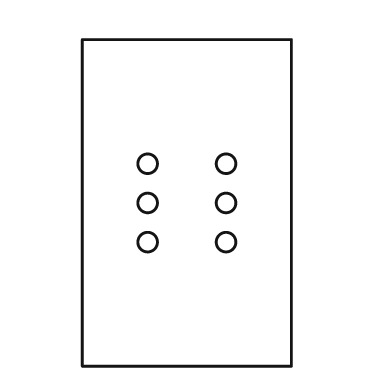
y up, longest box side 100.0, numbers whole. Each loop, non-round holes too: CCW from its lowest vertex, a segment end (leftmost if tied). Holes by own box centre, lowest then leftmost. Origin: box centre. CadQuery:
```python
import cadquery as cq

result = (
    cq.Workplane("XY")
    .moveTo(-32.0, -50.0)
    .lineTo(32.0, -50.0)
    .lineTo(32.0, 50.0)
    .lineTo(-32.0, 50.0)
    .close()
    .moveTo(-12.0, -12.0)
    .circle(3.0)
    .moveTo(12.0, -12.0)
    .circle(3.0)
    .moveTo(-12.0, 0.0)
    .circle(3.0)
    .moveTo(12.0, 0.0)
    .circle(3.0)
    .moveTo(-12.0, 12.0)
    .circle(3.0)
    .moveTo(12.0, 12.0)
    .circle(3.0)
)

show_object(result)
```